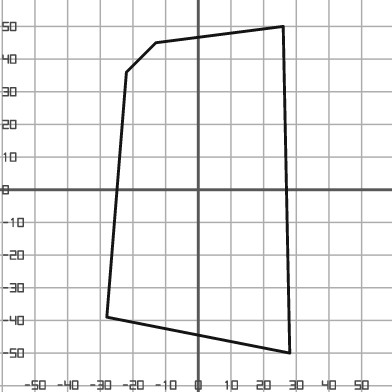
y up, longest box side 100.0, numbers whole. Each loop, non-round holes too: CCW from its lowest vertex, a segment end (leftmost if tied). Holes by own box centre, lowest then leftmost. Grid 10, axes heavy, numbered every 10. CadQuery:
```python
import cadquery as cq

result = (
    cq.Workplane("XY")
    .moveTo(28.0, -50.0)
    .lineTo(26.0, 50.0)
    .lineTo(-13.0, 45.0)
    .lineTo(-22.0, 36.0)
    .lineTo(-28.0, -39.0)
    .close()
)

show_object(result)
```